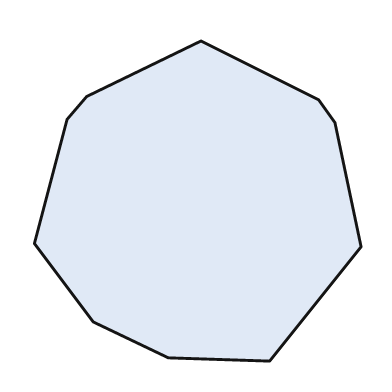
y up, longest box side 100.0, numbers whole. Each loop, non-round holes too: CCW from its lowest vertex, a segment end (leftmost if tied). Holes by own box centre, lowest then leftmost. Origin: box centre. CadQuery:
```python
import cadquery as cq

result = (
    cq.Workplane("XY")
    .moveTo(22.0, -49.0)
    .lineTo(50.0, -14.0)
    .lineTo(42.0, 24.0)
    .lineTo(37.0, 31.0)
    .lineTo(1.0, 49.0)
    .lineTo(-34.0, 32.0)
    .lineTo(-40.0, 25.0)
    .lineTo(-50.0, -13.0)
    .lineTo(-32.0, -37.0)
    .lineTo(-9.0, -48.0)
    .close()
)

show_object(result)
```